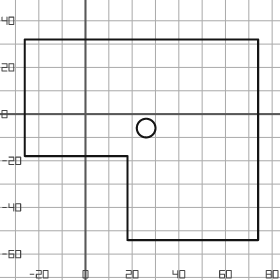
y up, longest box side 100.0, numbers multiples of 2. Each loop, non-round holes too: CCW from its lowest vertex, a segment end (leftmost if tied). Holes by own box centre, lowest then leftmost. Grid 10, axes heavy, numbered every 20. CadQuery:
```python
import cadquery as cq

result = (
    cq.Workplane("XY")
    .moveTo(18.0, -54.0)
    .lineTo(74.0, -54.0)
    .lineTo(74.0, 32.0)
    .lineTo(-26.0, 32.0)
    .lineTo(-26.0, -18.0)
    .lineTo(18.0, -18.0)
    .close()
    .moveTo(26.0, -6.0)
    .circle(4.0)
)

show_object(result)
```